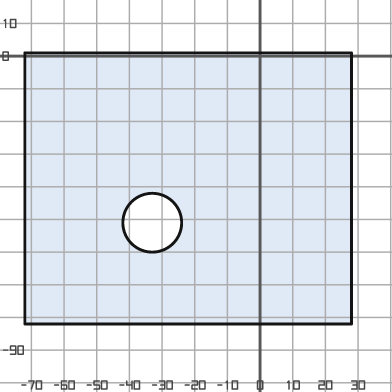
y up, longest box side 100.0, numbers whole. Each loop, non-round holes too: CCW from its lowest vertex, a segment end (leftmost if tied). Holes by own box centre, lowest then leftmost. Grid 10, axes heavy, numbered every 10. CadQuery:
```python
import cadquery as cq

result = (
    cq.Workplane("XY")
    .moveTo(-72.0, -82.0)
    .lineTo(28.0, -82.0)
    .lineTo(28.0, 1.0)
    .lineTo(-72.0, 1.0)
    .close()
    .moveTo(-33.0, -51.0)
    .circle(9.0)
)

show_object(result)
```